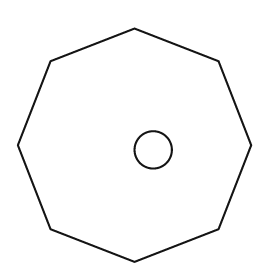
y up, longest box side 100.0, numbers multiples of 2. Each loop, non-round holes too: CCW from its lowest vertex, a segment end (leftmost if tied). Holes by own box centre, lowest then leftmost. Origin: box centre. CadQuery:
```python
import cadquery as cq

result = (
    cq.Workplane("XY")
    .moveTo(0.0, -50.0)
    .lineTo(36.0, -36.0)
    .lineTo(50.0, 0.0)
    .lineTo(36.0, 36.0)
    .lineTo(0.0, 50.0)
    .lineTo(-36.0, 36.0)
    .lineTo(-50.0, 0.0)
    .lineTo(-36.0, -36.0)
    .close()
    .moveTo(8.0, -2.0)
    .circle(8.0)
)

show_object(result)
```